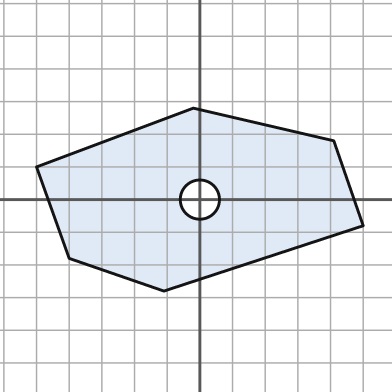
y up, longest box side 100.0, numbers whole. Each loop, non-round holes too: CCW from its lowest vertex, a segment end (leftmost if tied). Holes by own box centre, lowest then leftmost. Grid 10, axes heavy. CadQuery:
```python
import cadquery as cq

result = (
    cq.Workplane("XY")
    .moveTo(-11.0, -28.0)
    .lineTo(50.0, -8.0)
    .lineTo(41.0, 18.0)
    .lineTo(-2.0, 28.0)
    .lineTo(-50.0, 10.0)
    .lineTo(-40.0, -18.0)
    .close()
    .moveTo(0.0, 0.0)
    .circle(6.0)
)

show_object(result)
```